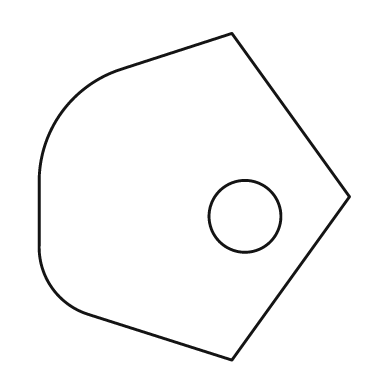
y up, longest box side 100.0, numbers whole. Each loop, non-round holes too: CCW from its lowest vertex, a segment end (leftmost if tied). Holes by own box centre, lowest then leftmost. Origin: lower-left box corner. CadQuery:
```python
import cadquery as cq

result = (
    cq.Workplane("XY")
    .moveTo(59.0, 0.0)
    .lineTo(95.0, 50.0)
    .lineTo(59.0, 100.0)
    .lineTo(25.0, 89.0)
    .threePointArc((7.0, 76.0), (0.0, 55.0))
    .lineTo(0.0, 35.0)
    .threePointArc((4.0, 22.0), (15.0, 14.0))
    .close()
    .moveTo(63.0, 44.0)
    .circle(11.0)
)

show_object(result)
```